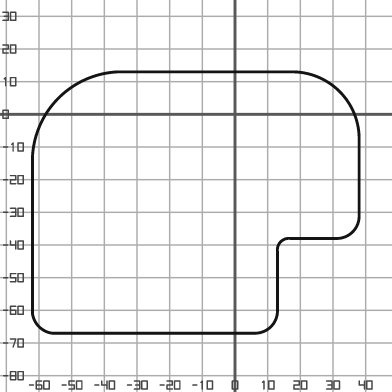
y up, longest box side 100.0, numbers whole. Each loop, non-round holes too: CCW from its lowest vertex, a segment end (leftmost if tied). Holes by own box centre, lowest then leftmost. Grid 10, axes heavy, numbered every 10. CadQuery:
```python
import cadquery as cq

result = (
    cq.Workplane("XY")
    .moveTo(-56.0, -67.0)
    .lineTo(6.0, -67.0)
    .threePointArc((11.0, -65.0), (13.0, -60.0))
    .lineTo(13.0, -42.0)
    .threePointArc((14.0, -39.0), (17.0, -38.0))
    .lineTo(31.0, -38.0)
    .threePointArc((36.0, -36.0), (38.0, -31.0))
    .lineTo(38.0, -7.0)
    .threePointArc((32.0, 7.0), (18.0, 13.0))
    .lineTo(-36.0, 13.0)
    .threePointArc((-54.0, 5.0), (-62.0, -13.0))
    .lineTo(-62.0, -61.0)
    .threePointArc((-60.0, -65.0), (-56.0, -67.0))
    .close()
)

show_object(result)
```